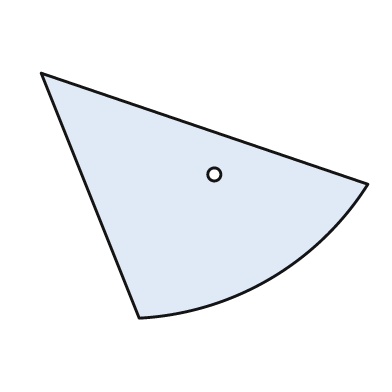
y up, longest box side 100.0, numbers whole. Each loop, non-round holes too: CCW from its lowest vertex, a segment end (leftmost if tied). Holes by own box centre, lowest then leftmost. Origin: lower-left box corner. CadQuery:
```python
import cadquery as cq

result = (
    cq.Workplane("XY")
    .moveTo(30.0, 0.0)
    .threePointArc((70.0, 12.0), (100.0, 41.0))
    .lineTo(0.0, 75.0)
    .close()
    .moveTo(53.0, 44.0)
    .circle(2.0)
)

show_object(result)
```